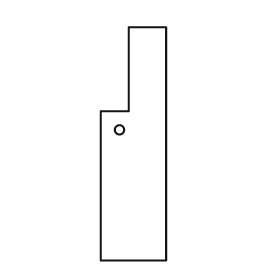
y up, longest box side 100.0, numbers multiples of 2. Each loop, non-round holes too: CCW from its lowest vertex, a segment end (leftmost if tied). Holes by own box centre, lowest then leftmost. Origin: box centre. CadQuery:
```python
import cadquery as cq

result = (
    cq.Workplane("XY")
    .moveTo(-14.0, -50.0)
    .lineTo(14.0, -50.0)
    .lineTo(14.0, 50.0)
    .lineTo(-2.0, 50.0)
    .lineTo(-2.0, 14.0)
    .lineTo(-14.0, 14.0)
    .close()
    .moveTo(-6.0, 6.0)
    .circle(2.0)
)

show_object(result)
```